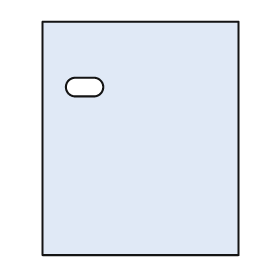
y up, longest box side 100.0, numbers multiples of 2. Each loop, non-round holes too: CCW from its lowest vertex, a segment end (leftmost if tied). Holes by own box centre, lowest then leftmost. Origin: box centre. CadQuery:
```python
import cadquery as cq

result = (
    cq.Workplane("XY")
    .moveTo(-42.0, -50.0)
    .lineTo(42.0, -50.0)
    .lineTo(42.0, 50.0)
    .lineTo(-42.0, 50.0)
    .close()
    .moveTo(-28.0, 18.0)
    .lineTo(-20.0, 18.0)
    .threePointArc((-16.0, 22.0), (-20.0, 26.0))
    .lineTo(-28.0, 26.0)
    .threePointArc((-32.0, 22.0), (-28.0, 18.0))
    .close()
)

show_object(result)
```